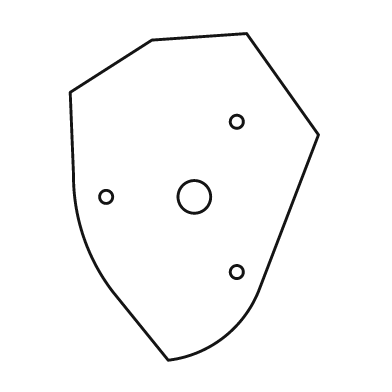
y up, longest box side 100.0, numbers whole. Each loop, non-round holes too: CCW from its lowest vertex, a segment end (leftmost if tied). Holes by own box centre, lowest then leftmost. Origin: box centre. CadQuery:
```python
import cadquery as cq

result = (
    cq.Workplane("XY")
    .moveTo(-8.0, -50.0)
    .threePointArc((9.0, -43.0), (20.0, -28.0))
    .lineTo(38.0, 19.0)
    .lineTo(16.0, 50.0)
    .lineTo(-13.0, 48.0)
    .lineTo(-38.0, 32.0)
    .lineTo(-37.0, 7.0)
    .threePointArc((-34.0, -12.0), (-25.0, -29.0))
    .close()
    .moveTo(13.0, -23.0)
    .circle(2.0)
    .moveTo(-27.0, 0.0)
    .circle(2.0)
    .moveTo(0.0, 0.0)
    .circle(5.0)
    .moveTo(13.0, 23.0)
    .circle(2.0)
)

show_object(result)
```